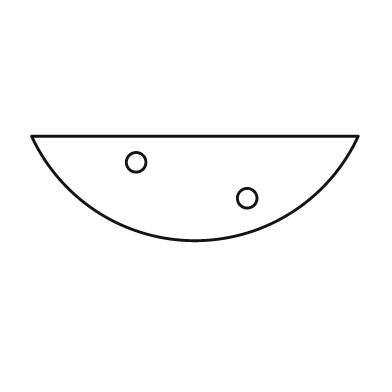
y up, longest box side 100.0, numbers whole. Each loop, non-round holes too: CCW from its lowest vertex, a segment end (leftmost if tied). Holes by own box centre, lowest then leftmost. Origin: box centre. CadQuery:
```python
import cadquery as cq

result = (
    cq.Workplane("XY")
    .moveTo(-50.0, 16.0)
    .threePointArc((0.0, -16.0), (50.0, 16.0))
    .close()
    .moveTo(16.0, -3.0)
    .circle(3.0)
    .moveTo(-18.0, 8.0)
    .circle(3.0)
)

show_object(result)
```